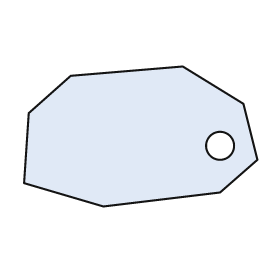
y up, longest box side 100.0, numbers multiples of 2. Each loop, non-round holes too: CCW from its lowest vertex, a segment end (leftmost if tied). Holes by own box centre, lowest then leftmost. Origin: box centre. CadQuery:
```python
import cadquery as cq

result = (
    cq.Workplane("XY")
    .moveTo(-16.0, -30.0)
    .lineTo(34.0, -24.0)
    .lineTo(50.0, -10.0)
    .lineTo(44.0, 14.0)
    .lineTo(18.0, 30.0)
    .lineTo(-30.0, 26.0)
    .lineTo(-48.0, 10.0)
    .lineTo(-50.0, -20.0)
    .close()
    .moveTo(34.0, -4.0)
    .circle(6.0)
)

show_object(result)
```